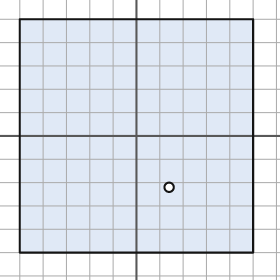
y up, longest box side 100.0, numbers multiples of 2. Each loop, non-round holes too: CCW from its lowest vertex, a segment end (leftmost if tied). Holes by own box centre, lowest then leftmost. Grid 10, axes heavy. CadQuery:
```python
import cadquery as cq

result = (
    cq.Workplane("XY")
    .moveTo(-50.0, -50.0)
    .lineTo(50.0, -50.0)
    .lineTo(50.0, 50.0)
    .lineTo(-50.0, 50.0)
    .close()
    .moveTo(14.0, -22.0)
    .circle(2.0)
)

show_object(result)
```